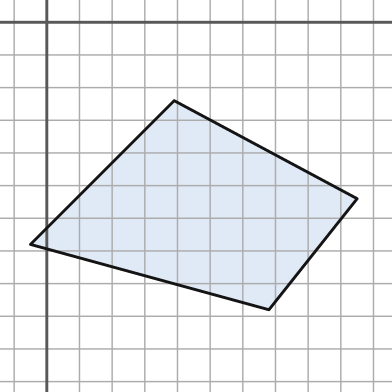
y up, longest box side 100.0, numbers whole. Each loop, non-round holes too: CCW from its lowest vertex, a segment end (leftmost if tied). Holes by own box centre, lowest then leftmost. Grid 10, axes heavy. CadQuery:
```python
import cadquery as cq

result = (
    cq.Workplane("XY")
    .moveTo(68.0, -88.0)
    .lineTo(95.0, -54.0)
    .lineTo(39.0, -24.0)
    .lineTo(-5.0, -68.0)
    .close()
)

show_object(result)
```